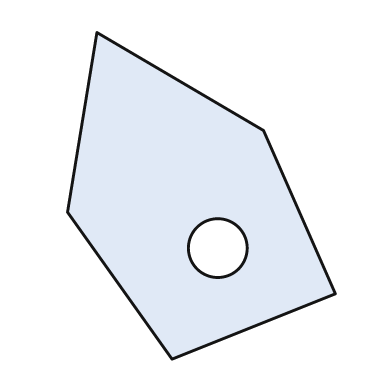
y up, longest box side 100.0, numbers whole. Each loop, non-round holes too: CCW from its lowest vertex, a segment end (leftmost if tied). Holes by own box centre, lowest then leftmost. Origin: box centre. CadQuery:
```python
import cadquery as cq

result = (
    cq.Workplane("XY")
    .moveTo(-9.0, -50.0)
    .lineTo(41.0, -30.0)
    .lineTo(19.0, 20.0)
    .lineTo(-32.0, 50.0)
    .lineTo(-41.0, -5.0)
    .close()
    .moveTo(5.0, -16.0)
    .circle(9.0)
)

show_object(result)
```